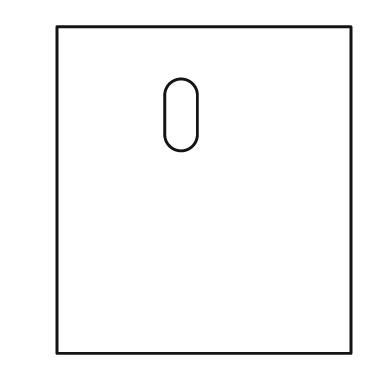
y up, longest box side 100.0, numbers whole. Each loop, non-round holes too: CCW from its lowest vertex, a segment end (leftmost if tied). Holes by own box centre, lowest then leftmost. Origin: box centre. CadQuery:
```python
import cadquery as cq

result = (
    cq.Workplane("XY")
    .moveTo(-45.0, -50.0)
    .lineTo(45.0, -50.0)
    .lineTo(45.0, 50.0)
    .lineTo(-45.0, 50.0)
    .close()
    .moveTo(-12.0, 17.0)
    .threePointArc((-7.0, 12.0), (-2.0, 17.0))
    .lineTo(-2.0, 29.0)
    .threePointArc((-7.0, 34.0), (-12.0, 29.0))
    .close()
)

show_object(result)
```